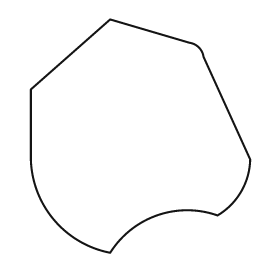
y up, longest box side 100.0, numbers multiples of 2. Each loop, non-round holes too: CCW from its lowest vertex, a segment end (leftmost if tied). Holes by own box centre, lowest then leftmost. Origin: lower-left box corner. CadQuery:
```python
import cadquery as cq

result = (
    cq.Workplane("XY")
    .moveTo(34.0, 0.0)
    .threePointArc((54.0, 16.0), (80.0, 16.0))
    .threePointArc((90.0, 26.0), (94.0, 40.0))
    .lineTo(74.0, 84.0)
    .threePointArc((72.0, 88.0), (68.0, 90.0))
    .lineTo(34.0, 100.0)
    .lineTo(0.0, 70.0)
    .lineTo(0.0, 40.0)
    .threePointArc((10.0, 14.0), (34.0, 0.0))
    .close()
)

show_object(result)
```